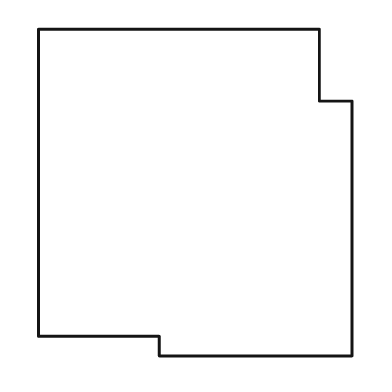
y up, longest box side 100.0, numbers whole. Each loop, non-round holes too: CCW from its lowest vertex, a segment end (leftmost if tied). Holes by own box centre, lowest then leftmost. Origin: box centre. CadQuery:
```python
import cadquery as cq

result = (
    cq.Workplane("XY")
    .moveTo(-11.0, -50.0)
    .lineTo(48.0, -50.0)
    .lineTo(48.0, 28.0)
    .lineTo(38.0, 28.0)
    .lineTo(38.0, 50.0)
    .lineTo(-48.0, 50.0)
    .lineTo(-48.0, -44.0)
    .lineTo(-11.0, -44.0)
    .close()
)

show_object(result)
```